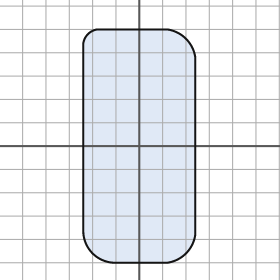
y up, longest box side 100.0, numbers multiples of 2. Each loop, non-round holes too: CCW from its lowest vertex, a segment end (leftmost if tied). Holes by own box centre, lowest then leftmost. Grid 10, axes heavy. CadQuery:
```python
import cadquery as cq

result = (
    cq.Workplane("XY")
    .moveTo(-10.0, -50.0)
    .lineTo(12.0, -50.0)
    .threePointArc((20.0, -46.0), (24.0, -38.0))
    .lineTo(24.0, 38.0)
    .threePointArc((20.0, 46.0), (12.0, 50.0))
    .lineTo(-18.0, 50.0)
    .threePointArc((-22.0, 48.0), (-24.0, 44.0))
    .lineTo(-24.0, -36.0)
    .threePointArc((-20.0, -46.0), (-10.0, -50.0))
    .close()
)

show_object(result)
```